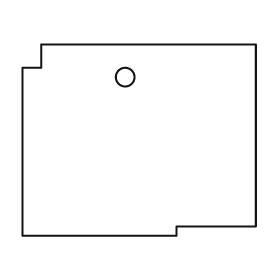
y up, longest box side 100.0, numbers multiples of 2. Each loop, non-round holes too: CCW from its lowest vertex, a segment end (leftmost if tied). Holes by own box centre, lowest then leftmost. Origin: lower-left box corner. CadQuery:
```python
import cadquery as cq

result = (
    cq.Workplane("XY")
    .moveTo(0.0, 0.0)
    .lineTo(66.0, 0.0)
    .lineTo(66.0, 4.0)
    .lineTo(100.0, 4.0)
    .lineTo(100.0, 82.0)
    .lineTo(8.0, 82.0)
    .lineTo(8.0, 72.0)
    .lineTo(0.0, 72.0)
    .close()
    .moveTo(44.0, 68.0)
    .circle(4.0)
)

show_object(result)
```